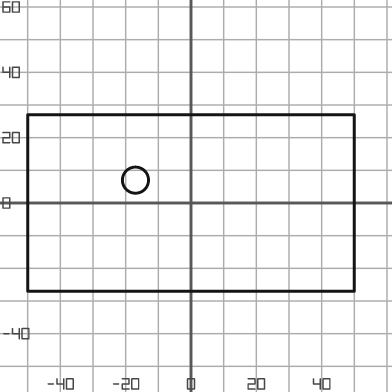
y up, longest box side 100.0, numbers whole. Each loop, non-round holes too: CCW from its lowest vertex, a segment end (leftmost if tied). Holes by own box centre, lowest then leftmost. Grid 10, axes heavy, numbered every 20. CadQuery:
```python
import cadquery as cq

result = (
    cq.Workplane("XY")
    .moveTo(-50.0, -27.0)
    .lineTo(50.0, -27.0)
    .lineTo(50.0, 27.0)
    .lineTo(-50.0, 27.0)
    .close()
    .moveTo(-17.0, 7.0)
    .circle(4.0)
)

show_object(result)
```